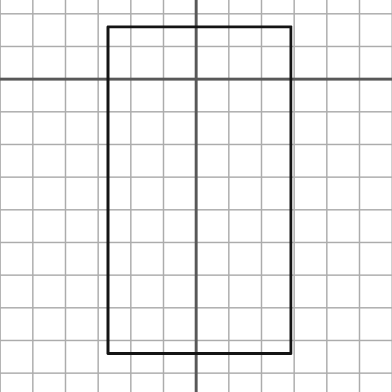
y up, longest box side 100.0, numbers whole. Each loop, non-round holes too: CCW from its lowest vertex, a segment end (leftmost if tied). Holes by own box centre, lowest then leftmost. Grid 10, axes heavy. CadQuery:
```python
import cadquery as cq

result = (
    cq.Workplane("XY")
    .moveTo(-27.0, -84.0)
    .lineTo(29.0, -84.0)
    .lineTo(29.0, 16.0)
    .lineTo(-27.0, 16.0)
    .close()
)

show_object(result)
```